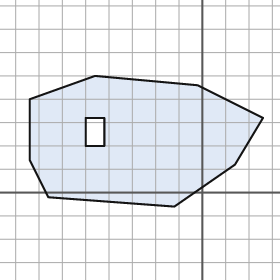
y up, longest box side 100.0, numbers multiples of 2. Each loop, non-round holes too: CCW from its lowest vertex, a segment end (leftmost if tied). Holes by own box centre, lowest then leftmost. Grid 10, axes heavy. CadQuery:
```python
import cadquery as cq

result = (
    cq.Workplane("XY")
    .moveTo(-12.0, -6.0)
    .lineTo(14.0, 12.0)
    .lineTo(26.0, 32.0)
    .lineTo(-2.0, 46.0)
    .lineTo(-46.0, 50.0)
    .lineTo(-74.0, 40.0)
    .lineTo(-74.0, 14.0)
    .lineTo(-66.0, -2.0)
    .close()
    .moveTo(-50.0, 20.0)
    .lineTo(-42.0, 20.0)
    .lineTo(-42.0, 32.0)
    .lineTo(-50.0, 32.0)
    .close()
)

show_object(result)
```